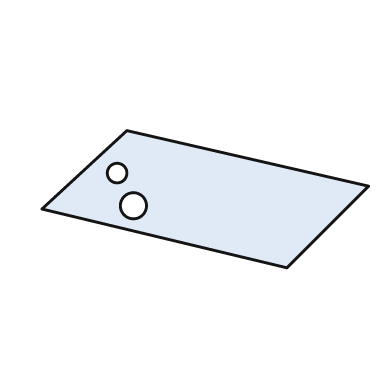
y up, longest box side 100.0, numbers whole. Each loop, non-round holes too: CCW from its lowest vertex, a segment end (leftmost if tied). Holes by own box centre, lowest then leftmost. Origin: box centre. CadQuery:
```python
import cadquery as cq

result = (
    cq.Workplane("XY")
    .moveTo(25.0, -21.0)
    .lineTo(50.0, 4.0)
    .lineTo(-24.0, 21.0)
    .lineTo(-50.0, -3.0)
    .close()
    .moveTo(-22.0, -2.0)
    .circle(4.0)
    .moveTo(-27.0, 8.0)
    .circle(3.0)
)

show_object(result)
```